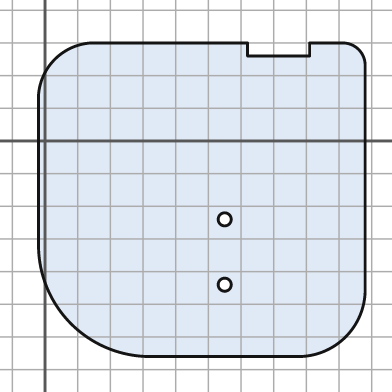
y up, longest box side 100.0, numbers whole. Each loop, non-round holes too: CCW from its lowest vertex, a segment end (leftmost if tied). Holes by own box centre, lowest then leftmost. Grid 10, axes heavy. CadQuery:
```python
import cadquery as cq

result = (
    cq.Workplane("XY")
    .moveTo(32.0, -66.0)
    .lineTo(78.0, -66.0)
    .threePointArc((92.0, -60.0), (98.0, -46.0))
    .lineTo(98.0, 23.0)
    .threePointArc((96.0, 28.0), (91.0, 30.0))
    .lineTo(81.0, 30.0)
    .lineTo(81.0, 26.0)
    .lineTo(62.0, 26.0)
    .lineTo(62.0, 30.0)
    .lineTo(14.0, 30.0)
    .threePointArc((3.0, 25.0), (-2.0, 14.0))
    .lineTo(-2.0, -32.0)
    .threePointArc((8.0, -56.0), (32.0, -66.0))
    .close()
    .moveTo(55.0, -44.0)
    .circle(2.0)
    .moveTo(55.0, -24.0)
    .circle(2.0)
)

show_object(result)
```